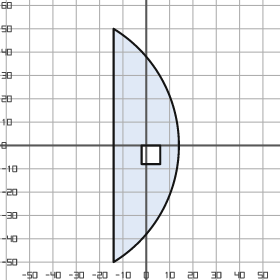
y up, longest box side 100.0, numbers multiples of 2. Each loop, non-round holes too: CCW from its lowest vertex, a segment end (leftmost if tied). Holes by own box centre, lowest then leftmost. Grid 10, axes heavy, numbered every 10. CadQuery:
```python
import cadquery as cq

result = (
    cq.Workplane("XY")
    .moveTo(-14.0, -50.0)
    .threePointArc((14.0, 0.0), (-14.0, 50.0))
    .close()
    .moveTo(-2.0, -8.0)
    .lineTo(6.0, -8.0)
    .lineTo(6.0, 0.0)
    .lineTo(-2.0, 0.0)
    .close()
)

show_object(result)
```